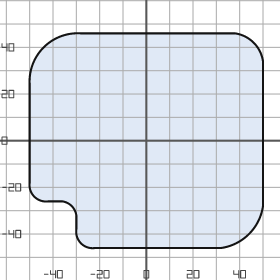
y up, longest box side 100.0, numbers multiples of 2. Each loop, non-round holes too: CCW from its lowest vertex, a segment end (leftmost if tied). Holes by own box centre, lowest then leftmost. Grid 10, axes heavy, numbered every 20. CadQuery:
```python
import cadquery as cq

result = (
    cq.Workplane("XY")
    .moveTo(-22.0, -46.0)
    .lineTo(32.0, -46.0)
    .threePointArc((44.0, -40.0), (50.0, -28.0))
    .lineTo(50.0, 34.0)
    .threePointArc((46.0, 42.0), (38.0, 46.0))
    .lineTo(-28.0, 46.0)
    .threePointArc((-44.0, 40.0), (-50.0, 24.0))
    .lineTo(-50.0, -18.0)
    .threePointArc((-48.0, -24.0), (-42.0, -26.0))
    .lineTo(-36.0, -26.0)
    .threePointArc((-32.0, -28.0), (-30.0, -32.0))
    .lineTo(-30.0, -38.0)
    .threePointArc((-28.0, -44.0), (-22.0, -46.0))
    .close()
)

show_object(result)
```